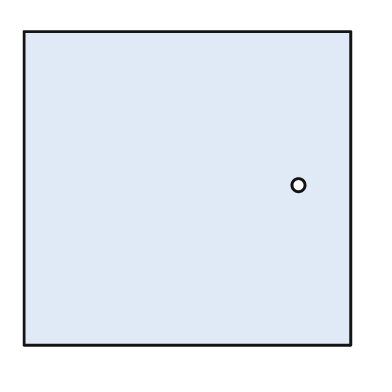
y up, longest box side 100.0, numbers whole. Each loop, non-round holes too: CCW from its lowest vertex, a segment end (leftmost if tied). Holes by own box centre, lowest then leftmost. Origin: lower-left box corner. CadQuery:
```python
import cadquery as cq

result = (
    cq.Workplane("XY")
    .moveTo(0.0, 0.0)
    .lineTo(100.0, 0.0)
    .lineTo(100.0, 96.0)
    .lineTo(0.0, 96.0)
    .close()
    .moveTo(84.0, 49.0)
    .circle(2.0)
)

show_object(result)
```